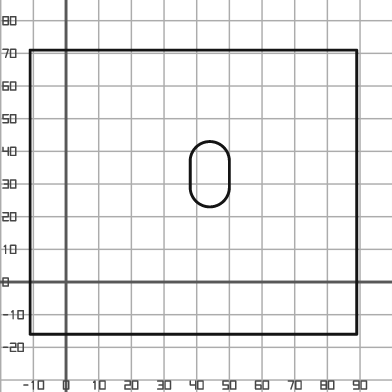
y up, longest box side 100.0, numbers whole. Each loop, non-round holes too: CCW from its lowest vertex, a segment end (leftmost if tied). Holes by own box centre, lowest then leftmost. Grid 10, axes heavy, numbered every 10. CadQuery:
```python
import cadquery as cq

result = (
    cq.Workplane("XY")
    .moveTo(-11.0, -16.0)
    .lineTo(89.0, -16.0)
    .lineTo(89.0, 71.0)
    .lineTo(-11.0, 71.0)
    .close()
    .moveTo(38.0, 29.0)
    .threePointArc((44.0, 23.0), (50.0, 29.0))
    .lineTo(50.0, 37.0)
    .threePointArc((44.0, 43.0), (38.0, 37.0))
    .close()
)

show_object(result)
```